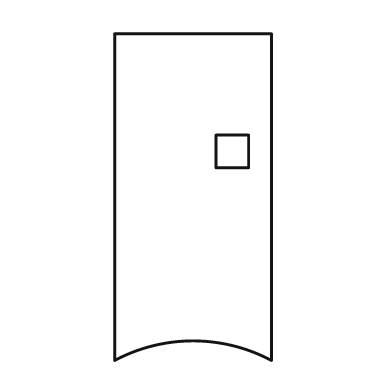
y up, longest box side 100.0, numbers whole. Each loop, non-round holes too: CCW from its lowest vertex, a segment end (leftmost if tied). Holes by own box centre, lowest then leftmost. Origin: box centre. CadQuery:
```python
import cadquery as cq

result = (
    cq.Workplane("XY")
    .moveTo(-24.0, -50.0)
    .threePointArc((0.0, -44.0), (24.0, -50.0))
    .lineTo(24.0, 50.0)
    .lineTo(-24.0, 50.0)
    .close()
    .moveTo(7.0, 9.0)
    .lineTo(17.0, 9.0)
    .lineTo(17.0, 19.0)
    .lineTo(7.0, 19.0)
    .close()
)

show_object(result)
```